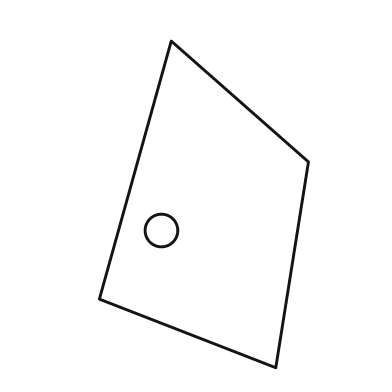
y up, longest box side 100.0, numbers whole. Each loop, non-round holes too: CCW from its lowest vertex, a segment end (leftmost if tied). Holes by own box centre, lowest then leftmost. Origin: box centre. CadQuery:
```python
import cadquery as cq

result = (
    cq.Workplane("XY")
    .moveTo(22.0, -50.0)
    .lineTo(32.0, 13.0)
    .lineTo(-10.0, 50.0)
    .lineTo(-32.0, -29.0)
    .close()
    .moveTo(-13.0, -8.0)
    .circle(5.0)
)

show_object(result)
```